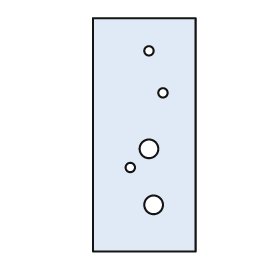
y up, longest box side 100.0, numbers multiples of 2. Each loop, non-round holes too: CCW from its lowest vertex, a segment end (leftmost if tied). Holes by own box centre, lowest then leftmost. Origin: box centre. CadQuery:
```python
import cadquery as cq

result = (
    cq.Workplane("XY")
    .moveTo(-22.0, -50.0)
    .lineTo(22.0, -50.0)
    .lineTo(22.0, 50.0)
    .lineTo(-22.0, 50.0)
    .close()
    .moveTo(4.0, -30.0)
    .circle(4.0)
    .moveTo(-6.0, -14.0)
    .circle(2.0)
    .moveTo(2.0, -6.0)
    .circle(4.0)
    .moveTo(8.0, 18.0)
    .circle(2.0)
    .moveTo(2.0, 36.0)
    .circle(2.0)
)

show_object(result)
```